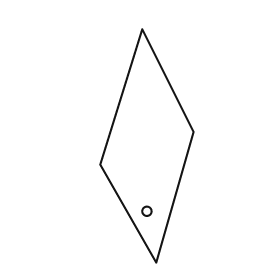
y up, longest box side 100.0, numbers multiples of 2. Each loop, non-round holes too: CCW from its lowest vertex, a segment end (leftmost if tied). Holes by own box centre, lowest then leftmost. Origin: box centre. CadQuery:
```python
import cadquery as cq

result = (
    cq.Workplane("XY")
    .moveTo(4.0, -50.0)
    .lineTo(20.0, 6.0)
    .lineTo(-2.0, 50.0)
    .lineTo(-20.0, -8.0)
    .close()
    .moveTo(0.0, -28.0)
    .circle(2.0)
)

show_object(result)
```